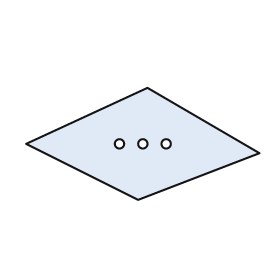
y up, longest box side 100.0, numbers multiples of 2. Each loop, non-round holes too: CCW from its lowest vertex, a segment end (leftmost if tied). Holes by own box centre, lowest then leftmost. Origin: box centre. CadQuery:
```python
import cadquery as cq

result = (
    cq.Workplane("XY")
    .moveTo(-2.0, -24.0)
    .lineTo(50.0, -4.0)
    .lineTo(2.0, 24.0)
    .lineTo(-50.0, 0.0)
    .close()
    .moveTo(-10.0, 0.0)
    .circle(2.0)
    .moveTo(0.0, 0.0)
    .circle(2.0)
    .moveTo(10.0, 0.0)
    .circle(2.0)
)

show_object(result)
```